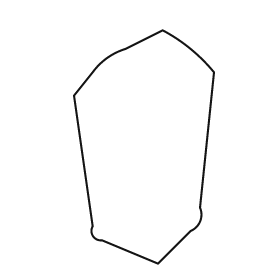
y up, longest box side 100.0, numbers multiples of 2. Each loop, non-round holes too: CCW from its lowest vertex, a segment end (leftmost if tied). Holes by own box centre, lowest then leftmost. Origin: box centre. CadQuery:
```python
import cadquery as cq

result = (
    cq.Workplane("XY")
    .moveTo(6.0, -50.0)
    .lineTo(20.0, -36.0)
    .threePointArc((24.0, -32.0), (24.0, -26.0))
    .lineTo(30.0, 32.0)
    .threePointArc((20.0, 42.0), (8.0, 50.0))
    .lineTo(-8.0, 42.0)
    .threePointArc((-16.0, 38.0), (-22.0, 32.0))
    .lineTo(-30.0, 22.0)
    .lineTo(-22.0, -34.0)
    .threePointArc((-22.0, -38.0), (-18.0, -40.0))
    .close()
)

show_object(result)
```